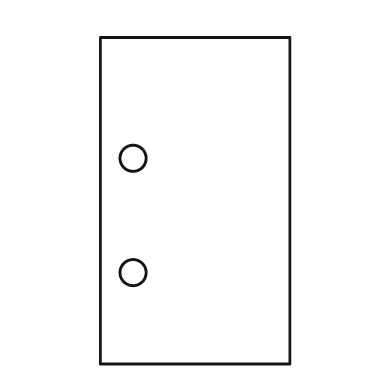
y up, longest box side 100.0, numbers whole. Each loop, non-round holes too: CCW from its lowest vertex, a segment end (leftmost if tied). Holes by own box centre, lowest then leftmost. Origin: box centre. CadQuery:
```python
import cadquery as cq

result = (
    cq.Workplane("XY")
    .moveTo(-29.0, -50.0)
    .lineTo(29.0, -50.0)
    .lineTo(29.0, 50.0)
    .lineTo(-29.0, 50.0)
    .close()
    .moveTo(-19.0, -22.0)
    .circle(4.0)
    .moveTo(-19.0, 13.0)
    .circle(4.0)
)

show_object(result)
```